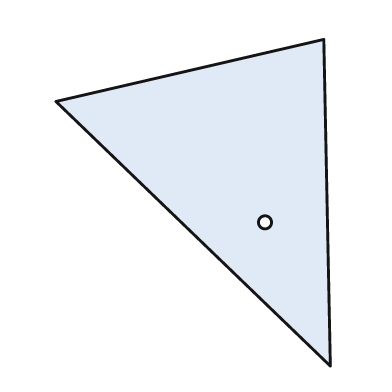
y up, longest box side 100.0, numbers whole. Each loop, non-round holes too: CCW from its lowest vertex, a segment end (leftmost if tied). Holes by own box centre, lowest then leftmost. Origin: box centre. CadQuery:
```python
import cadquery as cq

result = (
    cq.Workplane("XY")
    .moveTo(42.0, -50.0)
    .lineTo(40.0, 50.0)
    .lineTo(-42.0, 31.0)
    .close()
    .moveTo(22.0, -6.0)
    .circle(2.0)
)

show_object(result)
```